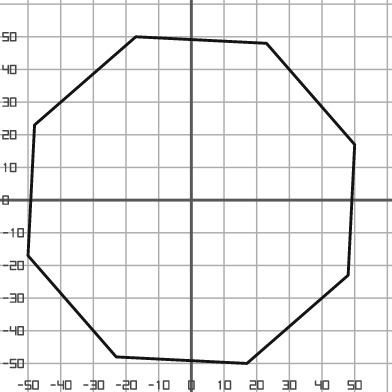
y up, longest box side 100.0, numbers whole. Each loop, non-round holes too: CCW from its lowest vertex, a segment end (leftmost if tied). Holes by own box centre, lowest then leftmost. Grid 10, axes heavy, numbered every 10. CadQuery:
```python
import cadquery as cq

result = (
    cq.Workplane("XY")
    .moveTo(17.0, -50.0)
    .lineTo(48.0, -23.0)
    .lineTo(50.0, 17.0)
    .lineTo(23.0, 48.0)
    .lineTo(-17.0, 50.0)
    .lineTo(-48.0, 23.0)
    .lineTo(-50.0, -17.0)
    .lineTo(-23.0, -48.0)
    .close()
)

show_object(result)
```